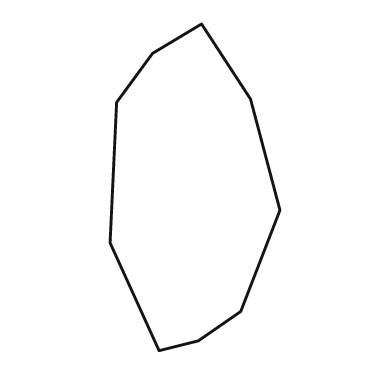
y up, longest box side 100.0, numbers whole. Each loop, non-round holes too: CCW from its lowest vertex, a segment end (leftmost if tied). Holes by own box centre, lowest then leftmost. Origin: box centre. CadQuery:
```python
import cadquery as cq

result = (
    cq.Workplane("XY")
    .moveTo(-11.0, -50.0)
    .lineTo(1.0, -47.0)
    .lineTo(14.0, -38.0)
    .lineTo(26.0, -7.0)
    .lineTo(17.0, 27.0)
    .lineTo(2.0, 50.0)
    .lineTo(-13.0, 41.0)
    .lineTo(-24.0, 26.0)
    .lineTo(-26.0, -17.0)
    .close()
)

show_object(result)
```